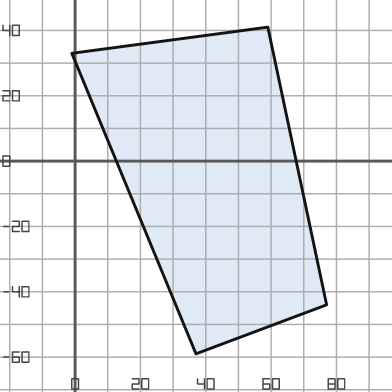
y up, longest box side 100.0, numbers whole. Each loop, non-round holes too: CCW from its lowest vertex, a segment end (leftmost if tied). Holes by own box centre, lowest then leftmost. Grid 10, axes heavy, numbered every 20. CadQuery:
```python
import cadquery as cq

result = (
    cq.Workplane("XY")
    .moveTo(37.0, -59.0)
    .lineTo(77.0, -44.0)
    .lineTo(59.0, 41.0)
    .lineTo(-1.0, 33.0)
    .close()
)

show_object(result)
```